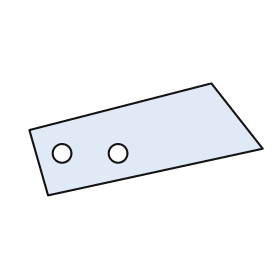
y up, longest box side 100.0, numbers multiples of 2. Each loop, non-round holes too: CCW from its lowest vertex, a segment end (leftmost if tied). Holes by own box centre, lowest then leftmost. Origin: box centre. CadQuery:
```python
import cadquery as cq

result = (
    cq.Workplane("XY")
    .moveTo(-42.0, -24.0)
    .lineTo(50.0, -4.0)
    .lineTo(28.0, 24.0)
    .lineTo(-50.0, 4.0)
    .close()
    .moveTo(-36.0, -6.0)
    .circle(4.0)
    .moveTo(-12.0, -6.0)
    .circle(4.0)
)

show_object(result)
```